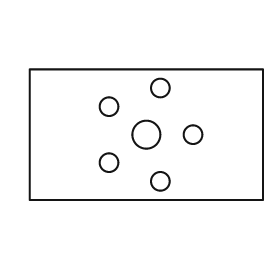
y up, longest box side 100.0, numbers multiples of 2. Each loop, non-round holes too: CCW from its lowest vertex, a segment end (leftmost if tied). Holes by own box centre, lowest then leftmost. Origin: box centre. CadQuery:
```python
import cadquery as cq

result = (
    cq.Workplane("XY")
    .moveTo(-50.0, -28.0)
    .lineTo(50.0, -28.0)
    .lineTo(50.0, 28.0)
    .lineTo(-50.0, 28.0)
    .close()
    .moveTo(6.0, -20.0)
    .circle(4.0)
    .moveTo(-16.0, -12.0)
    .circle(4.0)
    .moveTo(0.0, 0.0)
    .circle(6.0)
    .moveTo(20.0, 0.0)
    .circle(4.0)
    .moveTo(-16.0, 12.0)
    .circle(4.0)
    .moveTo(6.0, 20.0)
    .circle(4.0)
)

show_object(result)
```